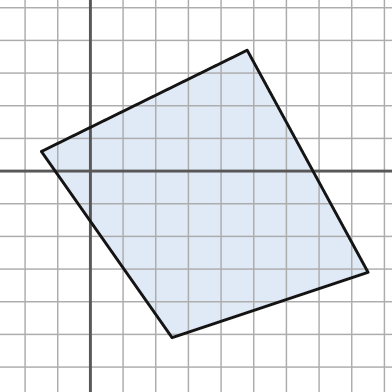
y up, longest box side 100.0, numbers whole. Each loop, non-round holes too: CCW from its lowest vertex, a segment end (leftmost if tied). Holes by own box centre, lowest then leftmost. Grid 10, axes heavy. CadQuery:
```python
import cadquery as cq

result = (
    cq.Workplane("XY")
    .moveTo(25.0, -51.0)
    .lineTo(85.0, -31.0)
    .lineTo(48.0, 37.0)
    .lineTo(-15.0, 6.0)
    .close()
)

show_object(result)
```